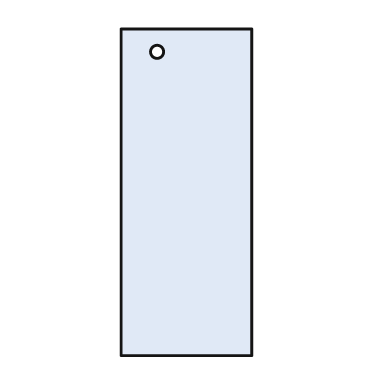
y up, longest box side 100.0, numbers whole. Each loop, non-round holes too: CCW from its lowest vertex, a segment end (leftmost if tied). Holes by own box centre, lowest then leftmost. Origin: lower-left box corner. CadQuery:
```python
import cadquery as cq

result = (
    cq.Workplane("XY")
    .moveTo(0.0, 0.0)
    .lineTo(40.0, 0.0)
    .lineTo(40.0, 100.0)
    .lineTo(0.0, 100.0)
    .close()
    .moveTo(11.0, 93.0)
    .circle(2.0)
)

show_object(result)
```